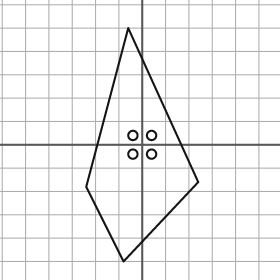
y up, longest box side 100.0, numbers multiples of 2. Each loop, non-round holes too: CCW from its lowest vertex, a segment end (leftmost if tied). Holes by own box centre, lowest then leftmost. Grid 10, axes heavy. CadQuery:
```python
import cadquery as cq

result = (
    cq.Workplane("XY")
    .moveTo(-8.0, -50.0)
    .lineTo(24.0, -16.0)
    .lineTo(-6.0, 50.0)
    .lineTo(-24.0, -18.0)
    .close()
    .moveTo(-4.0, -4.0)
    .circle(2.0)
    .moveTo(4.0, -4.0)
    .circle(2.0)
    .moveTo(-4.0, 4.0)
    .circle(2.0)
    .moveTo(4.0, 4.0)
    .circle(2.0)
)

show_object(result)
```